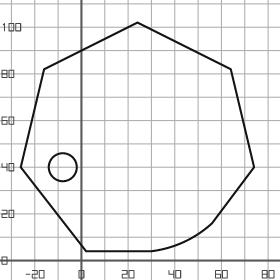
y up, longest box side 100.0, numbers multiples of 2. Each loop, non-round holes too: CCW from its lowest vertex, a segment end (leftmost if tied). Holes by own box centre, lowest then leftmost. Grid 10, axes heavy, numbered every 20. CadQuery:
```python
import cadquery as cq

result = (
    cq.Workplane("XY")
    .moveTo(2.0, 4.0)
    .lineTo(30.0, 4.0)
    .threePointArc((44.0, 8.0), (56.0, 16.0))
    .lineTo(74.0, 40.0)
    .lineTo(64.0, 82.0)
    .lineTo(24.0, 102.0)
    .lineTo(-16.0, 82.0)
    .lineTo(-26.0, 40.0)
    .close()
    .moveTo(-8.0, 40.0)
    .circle(6.0)
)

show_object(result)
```